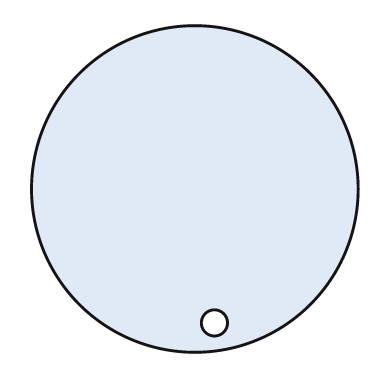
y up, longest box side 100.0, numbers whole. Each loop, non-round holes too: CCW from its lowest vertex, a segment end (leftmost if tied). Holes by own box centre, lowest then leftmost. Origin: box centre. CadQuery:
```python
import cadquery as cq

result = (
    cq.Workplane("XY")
    .moveTo(0.0, 0.0)
    .circle(50.0)
    .moveTo(6.0, -41.0)
    .circle(4.0)
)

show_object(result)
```